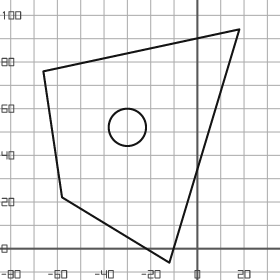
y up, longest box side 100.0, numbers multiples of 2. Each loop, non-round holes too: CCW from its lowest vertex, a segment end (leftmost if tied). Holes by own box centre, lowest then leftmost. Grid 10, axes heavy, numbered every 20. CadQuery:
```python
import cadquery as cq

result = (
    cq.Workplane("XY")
    .moveTo(-12.0, -6.0)
    .lineTo(18.0, 94.0)
    .lineTo(-66.0, 76.0)
    .lineTo(-58.0, 22.0)
    .close()
    .moveTo(-30.0, 52.0)
    .circle(8.0)
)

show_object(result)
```